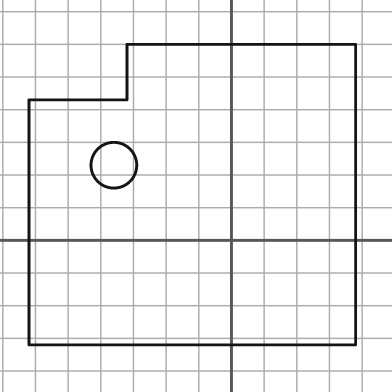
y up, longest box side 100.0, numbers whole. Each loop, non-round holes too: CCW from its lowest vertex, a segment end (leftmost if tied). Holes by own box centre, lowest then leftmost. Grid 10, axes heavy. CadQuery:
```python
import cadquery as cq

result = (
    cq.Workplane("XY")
    .moveTo(-62.0, -32.0)
    .lineTo(38.0, -32.0)
    .lineTo(38.0, 60.0)
    .lineTo(-32.0, 60.0)
    .lineTo(-32.0, 43.0)
    .lineTo(-62.0, 43.0)
    .close()
    .moveTo(-36.0, 23.0)
    .circle(7.0)
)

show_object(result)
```